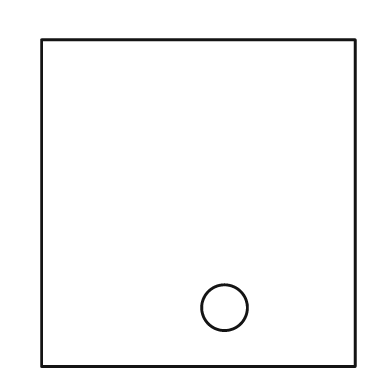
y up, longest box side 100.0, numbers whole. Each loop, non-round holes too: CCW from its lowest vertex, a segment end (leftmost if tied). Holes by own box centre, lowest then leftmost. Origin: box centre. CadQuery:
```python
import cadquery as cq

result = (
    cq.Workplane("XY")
    .moveTo(-48.0, -50.0)
    .lineTo(48.0, -50.0)
    .lineTo(48.0, 50.0)
    .lineTo(-48.0, 50.0)
    .close()
    .moveTo(8.0, -32.0)
    .circle(7.0)
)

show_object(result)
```